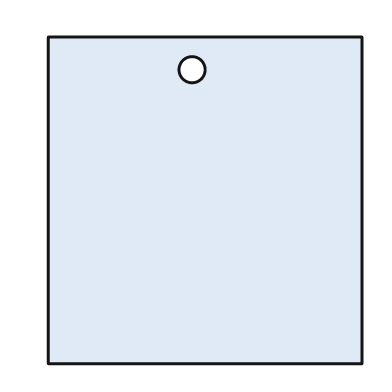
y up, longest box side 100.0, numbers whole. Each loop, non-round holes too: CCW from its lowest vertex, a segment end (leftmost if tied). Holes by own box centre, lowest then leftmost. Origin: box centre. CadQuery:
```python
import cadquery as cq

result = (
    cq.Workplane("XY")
    .moveTo(-48.0, -50.0)
    .lineTo(48.0, -50.0)
    .lineTo(48.0, 50.0)
    .lineTo(-48.0, 50.0)
    .close()
    .moveTo(-4.0, 40.0)
    .circle(4.0)
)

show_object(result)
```